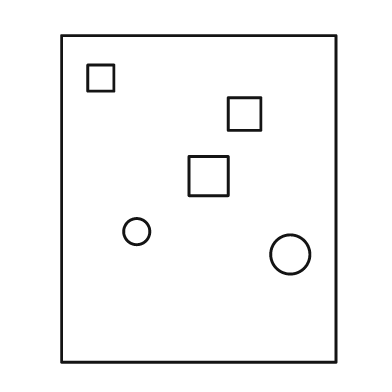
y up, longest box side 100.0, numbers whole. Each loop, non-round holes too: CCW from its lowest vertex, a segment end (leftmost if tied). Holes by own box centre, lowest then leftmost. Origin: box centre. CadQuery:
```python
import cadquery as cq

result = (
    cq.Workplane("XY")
    .moveTo(-42.0, -50.0)
    .lineTo(42.0, -50.0)
    .lineTo(42.0, 50.0)
    .lineTo(-42.0, 50.0)
    .close()
    .moveTo(28.0, -17.0)
    .circle(6.0)
    .moveTo(-19.0, -10.0)
    .circle(4.0)
    .moveTo(-3.0, 1.0)
    .lineTo(9.0, 1.0)
    .lineTo(9.0, 13.0)
    .lineTo(-3.0, 13.0)
    .close()
    .moveTo(9.0, 21.0)
    .lineTo(19.0, 21.0)
    .lineTo(19.0, 31.0)
    .lineTo(9.0, 31.0)
    .close()
    .moveTo(-34.0, 33.0)
    .lineTo(-26.0, 33.0)
    .lineTo(-26.0, 41.0)
    .lineTo(-34.0, 41.0)
    .close()
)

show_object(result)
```